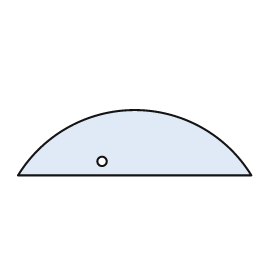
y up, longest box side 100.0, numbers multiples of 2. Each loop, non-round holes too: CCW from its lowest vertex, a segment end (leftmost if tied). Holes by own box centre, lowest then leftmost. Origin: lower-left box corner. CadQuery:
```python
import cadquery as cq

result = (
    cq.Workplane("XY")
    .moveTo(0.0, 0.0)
    .lineTo(100.0, 0.0)
    .threePointArc((50.0, 28.0), (0.0, 0.0))
    .close()
    .moveTo(36.0, 6.0)
    .circle(2.0)
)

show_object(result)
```